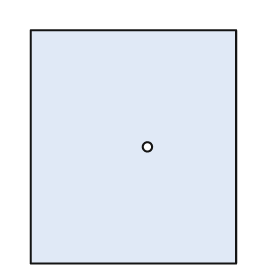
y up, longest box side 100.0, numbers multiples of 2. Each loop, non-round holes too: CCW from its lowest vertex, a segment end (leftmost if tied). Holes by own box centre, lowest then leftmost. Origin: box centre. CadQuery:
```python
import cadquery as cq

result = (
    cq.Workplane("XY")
    .moveTo(-44.0, -50.0)
    .lineTo(44.0, -50.0)
    .lineTo(44.0, 50.0)
    .lineTo(-44.0, 50.0)
    .close()
    .moveTo(6.0, 0.0)
    .circle(2.0)
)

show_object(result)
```